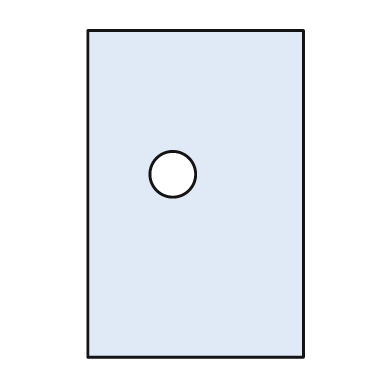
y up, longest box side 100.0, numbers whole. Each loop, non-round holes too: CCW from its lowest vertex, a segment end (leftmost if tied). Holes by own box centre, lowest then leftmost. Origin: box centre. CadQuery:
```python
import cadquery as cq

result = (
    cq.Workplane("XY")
    .moveTo(-33.0, -50.0)
    .lineTo(33.0, -50.0)
    .lineTo(33.0, 50.0)
    .lineTo(-33.0, 50.0)
    .close()
    .moveTo(-7.0, 6.0)
    .circle(7.0)
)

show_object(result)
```